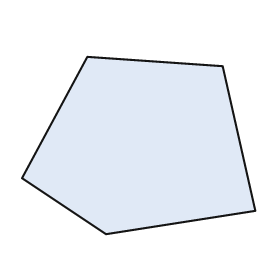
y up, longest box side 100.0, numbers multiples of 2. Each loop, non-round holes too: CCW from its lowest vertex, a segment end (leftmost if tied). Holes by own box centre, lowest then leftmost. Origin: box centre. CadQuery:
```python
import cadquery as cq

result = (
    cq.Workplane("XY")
    .moveTo(-14.0, -38.0)
    .lineTo(50.0, -28.0)
    .lineTo(36.0, 34.0)
    .lineTo(-22.0, 38.0)
    .lineTo(-50.0, -14.0)
    .close()
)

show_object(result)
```